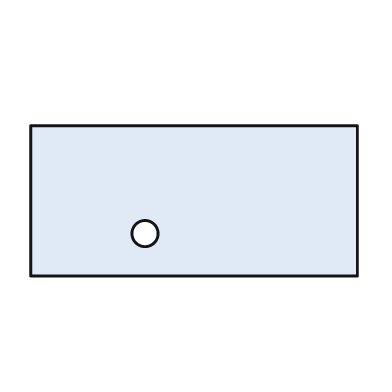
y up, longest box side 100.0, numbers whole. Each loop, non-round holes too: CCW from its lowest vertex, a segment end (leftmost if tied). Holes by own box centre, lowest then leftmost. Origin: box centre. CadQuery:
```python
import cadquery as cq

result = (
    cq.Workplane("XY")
    .moveTo(-50.0, -23.0)
    .lineTo(50.0, -23.0)
    .lineTo(50.0, 23.0)
    .lineTo(-50.0, 23.0)
    .close()
    .moveTo(-15.0, -10.0)
    .circle(4.0)
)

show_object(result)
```